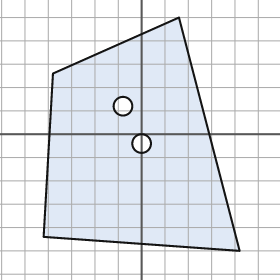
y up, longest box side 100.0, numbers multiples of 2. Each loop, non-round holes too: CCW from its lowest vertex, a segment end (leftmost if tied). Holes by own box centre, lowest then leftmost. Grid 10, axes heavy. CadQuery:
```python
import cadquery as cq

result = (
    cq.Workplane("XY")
    .moveTo(42.0, -50.0)
    .lineTo(16.0, 50.0)
    .lineTo(-38.0, 26.0)
    .lineTo(-42.0, -44.0)
    .close()
    .moveTo(0.0, -4.0)
    .circle(4.0)
    .moveTo(-8.0, 12.0)
    .circle(4.0)
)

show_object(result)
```